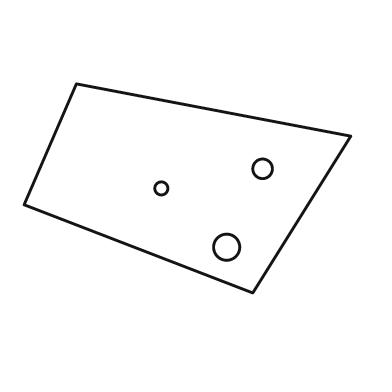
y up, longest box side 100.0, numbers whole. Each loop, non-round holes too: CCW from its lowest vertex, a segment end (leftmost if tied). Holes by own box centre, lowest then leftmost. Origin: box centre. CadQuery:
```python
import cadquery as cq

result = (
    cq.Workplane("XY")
    .moveTo(20.0, -32.0)
    .lineTo(50.0, 16.0)
    .lineTo(-34.0, 32.0)
    .lineTo(-50.0, -5.0)
    .close()
    .moveTo(12.0, -18.0)
    .circle(4.0)
    .moveTo(-8.0, 0.0)
    .circle(2.0)
    .moveTo(23.0, 6.0)
    .circle(3.0)
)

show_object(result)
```